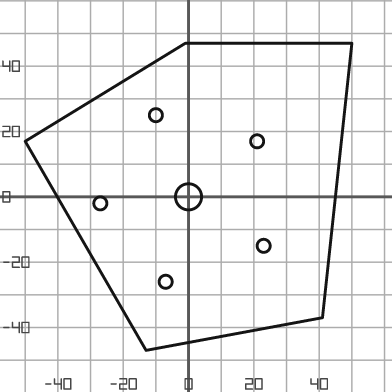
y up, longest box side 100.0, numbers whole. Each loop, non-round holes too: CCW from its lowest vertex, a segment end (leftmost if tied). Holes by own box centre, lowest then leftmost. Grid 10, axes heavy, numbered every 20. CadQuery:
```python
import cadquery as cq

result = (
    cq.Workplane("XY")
    .moveTo(-13.0, -47.0)
    .lineTo(41.0, -37.0)
    .lineTo(50.0, 47.0)
    .lineTo(-1.0, 47.0)
    .lineTo(-50.0, 17.0)
    .close()
    .moveTo(-7.0, -26.0)
    .circle(2.0)
    .moveTo(23.0, -15.0)
    .circle(2.0)
    .moveTo(-27.0, -2.0)
    .circle(2.0)
    .moveTo(0.0, 0.0)
    .circle(4.0)
    .moveTo(21.0, 17.0)
    .circle(2.0)
    .moveTo(-10.0, 25.0)
    .circle(2.0)
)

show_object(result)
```